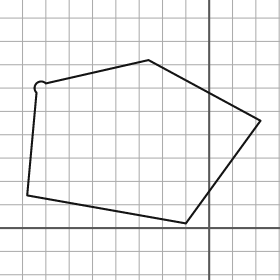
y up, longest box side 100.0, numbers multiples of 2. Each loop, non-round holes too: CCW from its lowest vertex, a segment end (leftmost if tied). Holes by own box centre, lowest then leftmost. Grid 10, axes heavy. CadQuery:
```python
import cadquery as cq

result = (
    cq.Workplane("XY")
    .moveTo(-10.0, 2.0)
    .lineTo(22.0, 46.0)
    .lineTo(-26.0, 72.0)
    .lineTo(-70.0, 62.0)
    .threePointArc((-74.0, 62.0), (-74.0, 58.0))
    .lineTo(-78.0, 14.0)
    .close()
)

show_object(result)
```